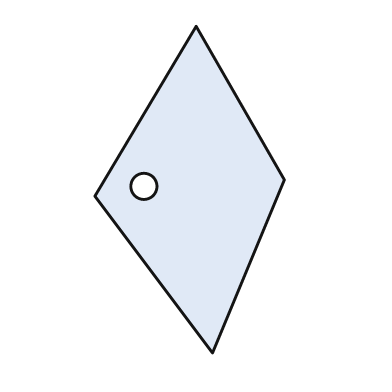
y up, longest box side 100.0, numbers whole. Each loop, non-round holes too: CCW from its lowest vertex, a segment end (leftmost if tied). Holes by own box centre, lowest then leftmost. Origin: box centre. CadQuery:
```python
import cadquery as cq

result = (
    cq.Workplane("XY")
    .moveTo(7.0, -50.0)
    .lineTo(29.0, 3.0)
    .lineTo(2.0, 50.0)
    .lineTo(-29.0, -2.0)
    .close()
    .moveTo(-14.0, 1.0)
    .circle(4.0)
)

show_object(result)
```